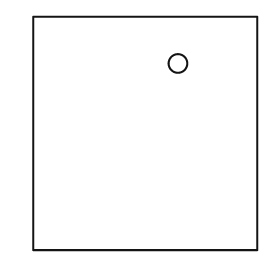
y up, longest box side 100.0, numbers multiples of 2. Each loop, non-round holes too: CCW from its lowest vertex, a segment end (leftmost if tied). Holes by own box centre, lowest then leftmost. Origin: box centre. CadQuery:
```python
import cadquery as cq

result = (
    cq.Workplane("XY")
    .moveTo(-48.0, -50.0)
    .lineTo(48.0, -50.0)
    .lineTo(48.0, 50.0)
    .lineTo(-48.0, 50.0)
    .close()
    .moveTo(14.0, 30.0)
    .circle(4.0)
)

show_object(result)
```